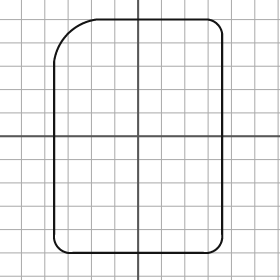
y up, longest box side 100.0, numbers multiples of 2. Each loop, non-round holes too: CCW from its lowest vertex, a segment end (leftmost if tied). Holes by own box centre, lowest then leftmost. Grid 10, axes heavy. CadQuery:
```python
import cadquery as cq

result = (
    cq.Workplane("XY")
    .moveTo(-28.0, -50.0)
    .lineTo(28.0, -50.0)
    .threePointArc((34.0, -48.0), (36.0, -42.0))
    .lineTo(36.0, 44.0)
    .threePointArc((34.0, 48.0), (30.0, 50.0))
    .lineTo(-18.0, 50.0)
    .threePointArc((-30.0, 44.0), (-36.0, 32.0))
    .lineTo(-36.0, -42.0)
    .threePointArc((-34.0, -48.0), (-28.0, -50.0))
    .close()
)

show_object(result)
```